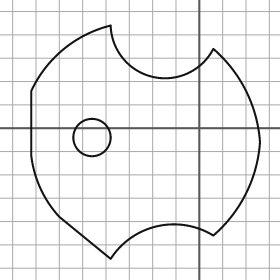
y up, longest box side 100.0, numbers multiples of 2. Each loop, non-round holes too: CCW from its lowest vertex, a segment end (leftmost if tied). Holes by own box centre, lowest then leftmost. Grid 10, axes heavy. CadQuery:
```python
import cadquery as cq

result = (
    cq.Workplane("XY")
    .moveTo(-38.0, -56.0)
    .threePointArc((-18.0, -42.0), (6.0, -46.0))
    .threePointArc((20.0, -28.0), (26.0, -6.0))
    .threePointArc((20.0, 16.0), (6.0, 34.0))
    .threePointArc((-20.0, 22.0), (-38.0, 44.0))
    .threePointArc((-58.0, 34.0), (-72.0, 16.0))
    .lineTo(-72.0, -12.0)
    .threePointArc((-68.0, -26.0), (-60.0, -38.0))
    .close()
    .moveTo(-46.0, -4.0)
    .circle(8.0)
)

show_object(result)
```